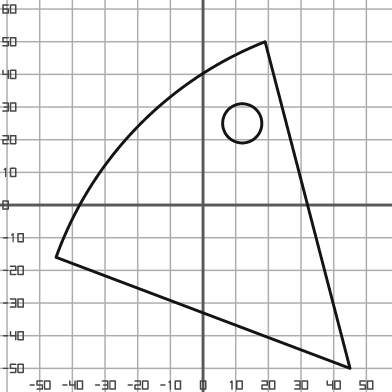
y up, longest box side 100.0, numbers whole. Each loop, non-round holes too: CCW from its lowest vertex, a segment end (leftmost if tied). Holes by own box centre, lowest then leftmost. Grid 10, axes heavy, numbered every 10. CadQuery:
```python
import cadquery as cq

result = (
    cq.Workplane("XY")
    .moveTo(45.0, -50.0)
    .lineTo(19.0, 50.0)
    .threePointArc((-20.0, 24.0), (-45.0, -16.0))
    .close()
    .moveTo(12.0, 25.0)
    .circle(6.0)
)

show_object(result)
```